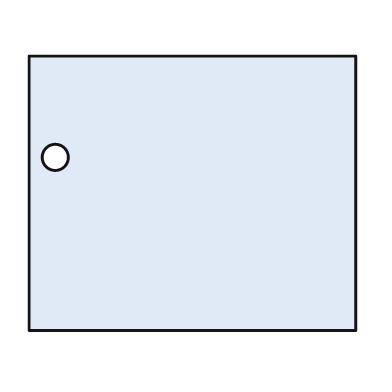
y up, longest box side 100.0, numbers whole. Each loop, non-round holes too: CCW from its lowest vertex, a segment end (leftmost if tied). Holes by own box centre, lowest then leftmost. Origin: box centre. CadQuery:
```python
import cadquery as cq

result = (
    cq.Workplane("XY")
    .moveTo(-50.0, -42.0)
    .lineTo(50.0, -42.0)
    .lineTo(50.0, 42.0)
    .lineTo(-50.0, 42.0)
    .close()
    .moveTo(-42.0, 11.0)
    .circle(4.0)
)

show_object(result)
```